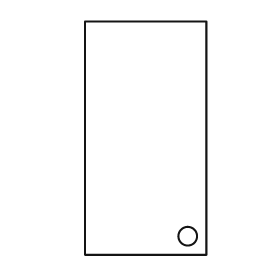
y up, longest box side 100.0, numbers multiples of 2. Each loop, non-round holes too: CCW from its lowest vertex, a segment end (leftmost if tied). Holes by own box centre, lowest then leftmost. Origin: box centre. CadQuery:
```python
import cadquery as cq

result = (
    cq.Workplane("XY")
    .moveTo(-26.0, -50.0)
    .lineTo(26.0, -50.0)
    .lineTo(26.0, 50.0)
    .lineTo(-26.0, 50.0)
    .close()
    .moveTo(18.0, -42.0)
    .circle(4.0)
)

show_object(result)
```